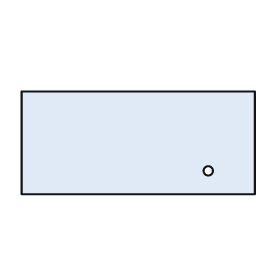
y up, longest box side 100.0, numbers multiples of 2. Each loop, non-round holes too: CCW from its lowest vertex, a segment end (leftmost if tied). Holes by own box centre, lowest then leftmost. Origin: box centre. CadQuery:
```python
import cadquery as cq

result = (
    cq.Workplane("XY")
    .moveTo(-50.0, -22.0)
    .lineTo(50.0, -22.0)
    .lineTo(50.0, 22.0)
    .lineTo(-50.0, 22.0)
    .close()
    .moveTo(30.0, -12.0)
    .circle(2.0)
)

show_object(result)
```